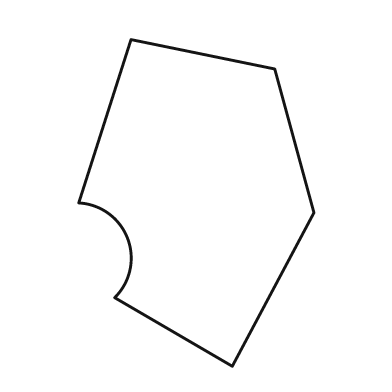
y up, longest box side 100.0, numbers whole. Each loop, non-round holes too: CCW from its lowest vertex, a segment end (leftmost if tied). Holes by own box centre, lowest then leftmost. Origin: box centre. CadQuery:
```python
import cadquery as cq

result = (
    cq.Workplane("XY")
    .moveTo(11.0, -50.0)
    .lineTo(36.0, -3.0)
    .lineTo(24.0, 41.0)
    .lineTo(-20.0, 50.0)
    .lineTo(-36.0, 0.0)
    .threePointArc((-21.0, -11.0), (-25.0, -29.0))
    .close()
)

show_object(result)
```